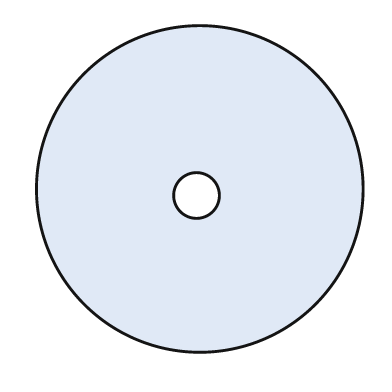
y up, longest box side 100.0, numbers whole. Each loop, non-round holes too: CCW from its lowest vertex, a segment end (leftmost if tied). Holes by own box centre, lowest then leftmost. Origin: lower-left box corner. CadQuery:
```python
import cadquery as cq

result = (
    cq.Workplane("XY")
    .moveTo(50.0, 50.0)
    .circle(50.0)
    .moveTo(49.0, 48.0)
    .circle(7.0)
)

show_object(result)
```